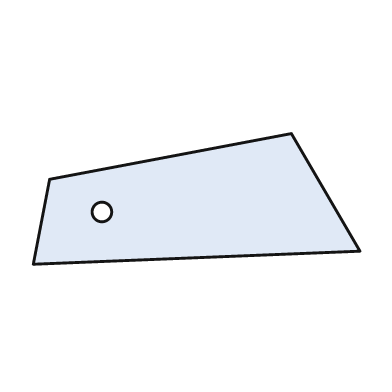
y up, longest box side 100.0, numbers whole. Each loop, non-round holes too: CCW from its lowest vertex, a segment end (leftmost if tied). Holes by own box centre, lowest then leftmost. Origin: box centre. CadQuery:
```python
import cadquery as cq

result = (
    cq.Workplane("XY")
    .moveTo(-50.0, -20.0)
    .lineTo(50.0, -16.0)
    .lineTo(29.0, 20.0)
    .lineTo(-45.0, 6.0)
    .close()
    .moveTo(-29.0, -4.0)
    .circle(3.0)
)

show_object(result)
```